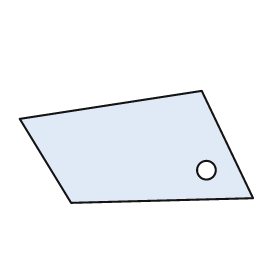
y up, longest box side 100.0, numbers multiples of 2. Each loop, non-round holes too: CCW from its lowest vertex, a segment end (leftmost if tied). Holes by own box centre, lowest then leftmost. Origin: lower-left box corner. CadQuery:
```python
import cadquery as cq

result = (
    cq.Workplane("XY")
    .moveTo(22.0, 0.0)
    .lineTo(100.0, 2.0)
    .lineTo(78.0, 48.0)
    .lineTo(0.0, 36.0)
    .close()
    .moveTo(80.0, 14.0)
    .circle(4.0)
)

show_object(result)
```